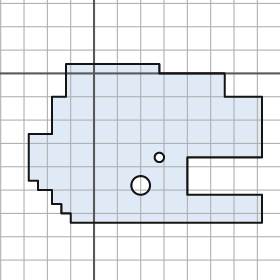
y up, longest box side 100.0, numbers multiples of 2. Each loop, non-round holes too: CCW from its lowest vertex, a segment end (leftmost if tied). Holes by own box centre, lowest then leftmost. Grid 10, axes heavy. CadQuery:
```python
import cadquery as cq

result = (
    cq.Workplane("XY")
    .moveTo(-10.0, -64.0)
    .lineTo(72.0, -64.0)
    .lineTo(72.0, -52.0)
    .lineTo(40.0, -52.0)
    .lineTo(40.0, -36.0)
    .lineTo(72.0, -36.0)
    .lineTo(72.0, -10.0)
    .lineTo(56.0, -10.0)
    .lineTo(56.0, 0.0)
    .lineTo(28.0, 0.0)
    .lineTo(28.0, 4.0)
    .lineTo(-12.0, 4.0)
    .lineTo(-12.0, -10.0)
    .lineTo(-18.0, -10.0)
    .lineTo(-18.0, -26.0)
    .lineTo(-28.0, -26.0)
    .lineTo(-28.0, -46.0)
    .lineTo(-24.0, -46.0)
    .lineTo(-24.0, -50.0)
    .lineTo(-18.0, -50.0)
    .lineTo(-18.0, -56.0)
    .lineTo(-14.0, -56.0)
    .lineTo(-14.0, -60.0)
    .lineTo(-10.0, -60.0)
    .close()
    .moveTo(20.0, -48.0)
    .circle(4.0)
    .moveTo(28.0, -36.0)
    .circle(2.0)
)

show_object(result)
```